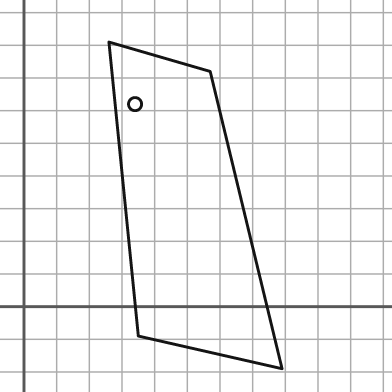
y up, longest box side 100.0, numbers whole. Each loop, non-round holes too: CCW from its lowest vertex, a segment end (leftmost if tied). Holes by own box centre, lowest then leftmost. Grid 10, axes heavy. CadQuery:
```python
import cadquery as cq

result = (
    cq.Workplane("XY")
    .moveTo(79.0, -19.0)
    .lineTo(57.0, 72.0)
    .lineTo(26.0, 81.0)
    .lineTo(35.0, -9.0)
    .close()
    .moveTo(34.0, 62.0)
    .circle(2.0)
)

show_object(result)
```